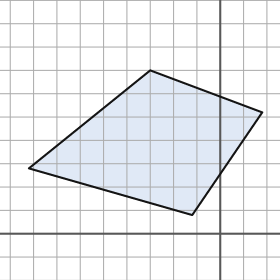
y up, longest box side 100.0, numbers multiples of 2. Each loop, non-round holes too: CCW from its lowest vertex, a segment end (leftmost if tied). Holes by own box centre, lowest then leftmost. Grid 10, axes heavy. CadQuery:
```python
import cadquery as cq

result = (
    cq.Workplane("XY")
    .moveTo(-12.0, 8.0)
    .lineTo(18.0, 52.0)
    .lineTo(-30.0, 70.0)
    .lineTo(-82.0, 28.0)
    .close()
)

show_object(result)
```